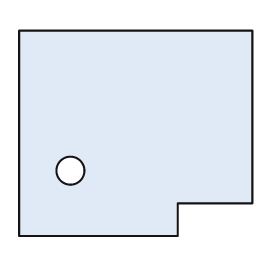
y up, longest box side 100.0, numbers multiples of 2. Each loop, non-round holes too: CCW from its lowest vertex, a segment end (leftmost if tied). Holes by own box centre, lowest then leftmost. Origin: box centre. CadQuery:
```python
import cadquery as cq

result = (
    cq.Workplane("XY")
    .moveTo(-50.0, -44.0)
    .lineTo(18.0, -44.0)
    .lineTo(18.0, -30.0)
    .lineTo(50.0, -30.0)
    .lineTo(50.0, 44.0)
    .lineTo(-50.0, 44.0)
    .close()
    .moveTo(-28.0, -16.0)
    .circle(6.0)
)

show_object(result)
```